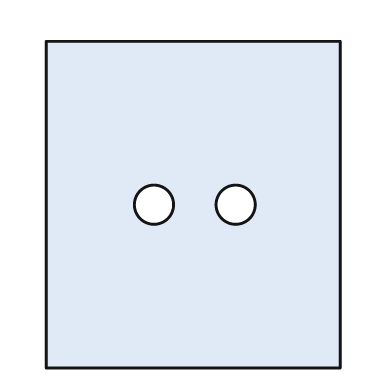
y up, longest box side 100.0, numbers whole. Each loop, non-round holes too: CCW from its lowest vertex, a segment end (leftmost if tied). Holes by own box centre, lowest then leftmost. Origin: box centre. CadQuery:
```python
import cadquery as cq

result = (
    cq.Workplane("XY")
    .moveTo(-45.0, -50.0)
    .lineTo(45.0, -50.0)
    .lineTo(45.0, 50.0)
    .lineTo(-45.0, 50.0)
    .close()
    .moveTo(-12.0, 0.0)
    .circle(6.0)
    .moveTo(13.0, 0.0)
    .circle(6.0)
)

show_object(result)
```